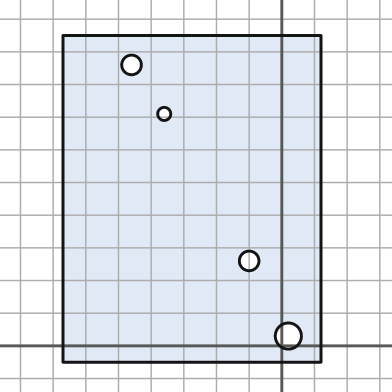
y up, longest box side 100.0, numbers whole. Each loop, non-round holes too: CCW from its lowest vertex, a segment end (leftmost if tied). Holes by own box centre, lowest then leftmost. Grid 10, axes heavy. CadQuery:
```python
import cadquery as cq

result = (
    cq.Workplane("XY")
    .moveTo(-67.0, -5.0)
    .lineTo(12.0, -5.0)
    .lineTo(12.0, 95.0)
    .lineTo(-67.0, 95.0)
    .close()
    .moveTo(2.0, 3.0)
    .circle(4.0)
    .moveTo(-10.0, 26.0)
    .circle(3.0)
    .moveTo(-36.0, 71.0)
    .circle(2.0)
    .moveTo(-46.0, 86.0)
    .circle(3.0)
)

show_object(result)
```